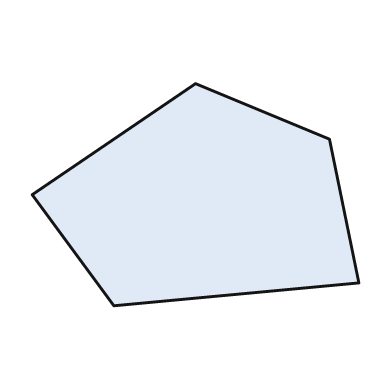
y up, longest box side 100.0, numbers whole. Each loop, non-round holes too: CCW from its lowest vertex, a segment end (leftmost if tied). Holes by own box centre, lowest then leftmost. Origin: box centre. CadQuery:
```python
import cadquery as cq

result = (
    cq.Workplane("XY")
    .moveTo(-25.0, -34.0)
    .lineTo(50.0, -27.0)
    .lineTo(41.0, 17.0)
    .lineTo(0.0, 34.0)
    .lineTo(-50.0, 0.0)
    .close()
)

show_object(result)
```